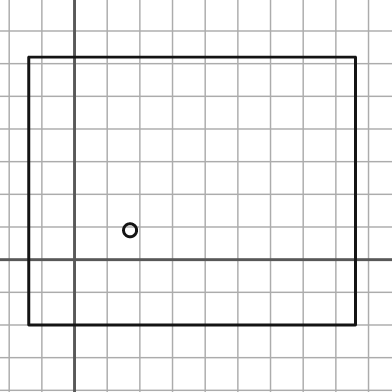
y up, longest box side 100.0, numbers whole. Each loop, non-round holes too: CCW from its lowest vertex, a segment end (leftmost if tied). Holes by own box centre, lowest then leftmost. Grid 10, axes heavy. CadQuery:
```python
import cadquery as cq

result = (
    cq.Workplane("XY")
    .moveTo(-14.0, -20.0)
    .lineTo(86.0, -20.0)
    .lineTo(86.0, 62.0)
    .lineTo(-14.0, 62.0)
    .close()
    .moveTo(17.0, 9.0)
    .circle(2.0)
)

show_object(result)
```